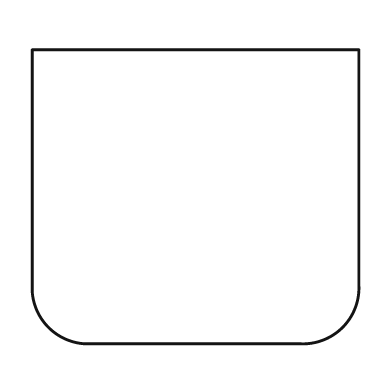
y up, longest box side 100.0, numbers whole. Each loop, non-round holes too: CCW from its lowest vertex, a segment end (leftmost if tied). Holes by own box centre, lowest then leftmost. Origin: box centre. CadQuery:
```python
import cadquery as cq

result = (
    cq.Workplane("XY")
    .moveTo(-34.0, -45.0)
    .lineTo(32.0, -45.0)
    .threePointArc((45.0, -40.0), (50.0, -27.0))
    .lineTo(50.0, 45.0)
    .lineTo(-50.0, 45.0)
    .lineTo(-50.0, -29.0)
    .threePointArc((-45.0, -40.0), (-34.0, -45.0))
    .close()
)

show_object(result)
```